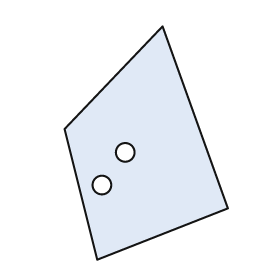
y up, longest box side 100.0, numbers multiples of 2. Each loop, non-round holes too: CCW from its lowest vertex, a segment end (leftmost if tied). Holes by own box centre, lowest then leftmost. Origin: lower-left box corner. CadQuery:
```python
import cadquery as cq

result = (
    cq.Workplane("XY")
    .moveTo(14.0, 0.0)
    .lineTo(70.0, 22.0)
    .lineTo(42.0, 100.0)
    .lineTo(0.0, 56.0)
    .close()
    .moveTo(16.0, 32.0)
    .circle(4.0)
    .moveTo(26.0, 46.0)
    .circle(4.0)
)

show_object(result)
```